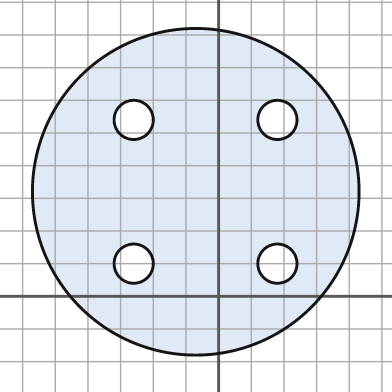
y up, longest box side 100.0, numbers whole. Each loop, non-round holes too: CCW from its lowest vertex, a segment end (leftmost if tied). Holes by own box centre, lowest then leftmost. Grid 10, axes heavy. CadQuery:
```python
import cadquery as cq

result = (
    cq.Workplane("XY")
    .moveTo(-7.0, 32.0)
    .circle(50.0)
    .moveTo(-26.0, 10.0)
    .circle(6.0)
    .moveTo(18.0, 10.0)
    .circle(6.0)
    .moveTo(-26.0, 54.0)
    .circle(6.0)
    .moveTo(18.0, 54.0)
    .circle(6.0)
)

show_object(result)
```